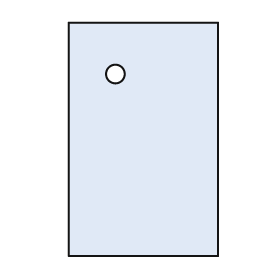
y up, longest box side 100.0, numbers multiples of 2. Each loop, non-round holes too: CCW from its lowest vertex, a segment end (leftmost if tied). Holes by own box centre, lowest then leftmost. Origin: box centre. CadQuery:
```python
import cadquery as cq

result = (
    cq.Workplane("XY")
    .moveTo(-32.0, -50.0)
    .lineTo(32.0, -50.0)
    .lineTo(32.0, 50.0)
    .lineTo(-32.0, 50.0)
    .close()
    .moveTo(-12.0, 28.0)
    .circle(4.0)
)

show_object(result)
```